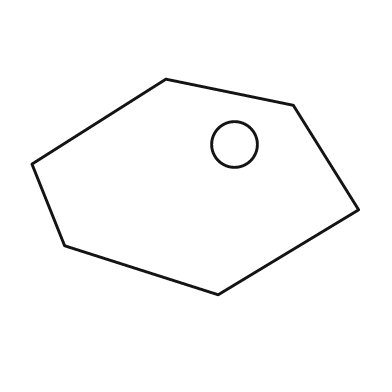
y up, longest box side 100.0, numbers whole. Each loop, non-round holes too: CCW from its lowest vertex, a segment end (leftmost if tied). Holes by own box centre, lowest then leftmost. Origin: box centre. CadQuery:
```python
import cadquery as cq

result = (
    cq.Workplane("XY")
    .moveTo(7.0, -33.0)
    .lineTo(50.0, -7.0)
    .lineTo(30.0, 25.0)
    .lineTo(-9.0, 33.0)
    .lineTo(-50.0, 7.0)
    .lineTo(-40.0, -18.0)
    .close()
    .moveTo(12.0, 13.0)
    .circle(7.0)
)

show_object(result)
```